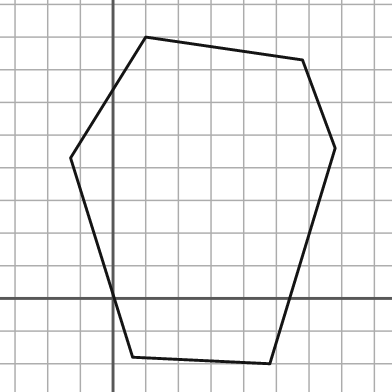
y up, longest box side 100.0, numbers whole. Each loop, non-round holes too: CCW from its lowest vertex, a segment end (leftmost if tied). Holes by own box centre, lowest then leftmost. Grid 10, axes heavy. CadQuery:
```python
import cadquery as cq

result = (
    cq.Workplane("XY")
    .moveTo(48.0, -20.0)
    .lineTo(68.0, 46.0)
    .lineTo(58.0, 73.0)
    .lineTo(10.0, 80.0)
    .lineTo(-13.0, 43.0)
    .lineTo(6.0, -18.0)
    .close()
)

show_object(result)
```